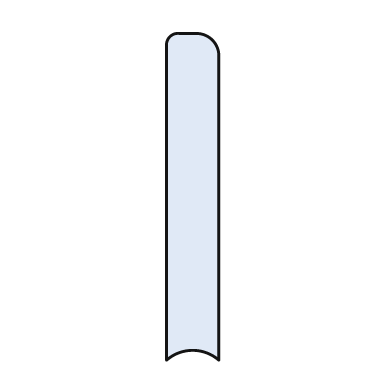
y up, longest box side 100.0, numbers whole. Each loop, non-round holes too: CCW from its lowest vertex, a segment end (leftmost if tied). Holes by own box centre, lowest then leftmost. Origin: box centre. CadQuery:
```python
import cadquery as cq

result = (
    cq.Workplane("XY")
    .moveTo(-8.0, -50.0)
    .threePointArc((0.0, -47.0), (8.0, -50.0))
    .lineTo(8.0, 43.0)
    .threePointArc((6.0, 48.0), (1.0, 50.0))
    .lineTo(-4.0, 50.0)
    .threePointArc((-7.0, 49.0), (-8.0, 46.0))
    .close()
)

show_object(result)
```